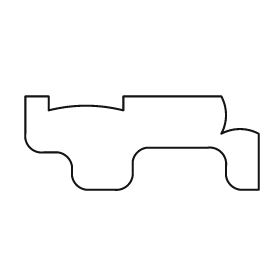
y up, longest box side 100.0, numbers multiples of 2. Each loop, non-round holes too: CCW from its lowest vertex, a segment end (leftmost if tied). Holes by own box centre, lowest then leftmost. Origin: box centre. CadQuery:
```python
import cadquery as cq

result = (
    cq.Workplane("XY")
    .moveTo(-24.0, -20.0)
    .lineTo(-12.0, -20.0)
    .threePointArc((-6.0, -18.0), (-4.0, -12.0))
    .lineTo(-4.0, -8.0)
    .threePointArc((-2.0, -4.0), (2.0, -2.0))
    .lineTo(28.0, -2.0)
    .threePointArc((34.0, -4.0), (36.0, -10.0))
    .lineTo(36.0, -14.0)
    .threePointArc((38.0, -18.0), (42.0, -20.0))
    .lineTo(50.0, -20.0)
    .lineTo(50.0, 4.0)
    .threePointArc((42.0, 6.0), (34.0, 4.0))
    .threePointArc((36.0, 12.0), (34.0, 20.0))
    .lineTo(-8.0, 20.0)
    .lineTo(-8.0, 14.0)
    .threePointArc((-24.0, 16.0), (-40.0, 14.0))
    .lineTo(-40.0, 20.0)
    .lineTo(-50.0, 20.0)
    .lineTo(-50.0, 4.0)
    .threePointArc((-48.0, -2.0), (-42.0, -4.0))
    .lineTo(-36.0, -4.0)
    .threePointArc((-32.0, -6.0), (-30.0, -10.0))
    .lineTo(-30.0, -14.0)
    .threePointArc((-28.0, -18.0), (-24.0, -20.0))
    .close()
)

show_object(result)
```